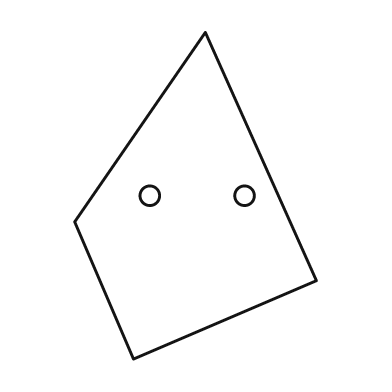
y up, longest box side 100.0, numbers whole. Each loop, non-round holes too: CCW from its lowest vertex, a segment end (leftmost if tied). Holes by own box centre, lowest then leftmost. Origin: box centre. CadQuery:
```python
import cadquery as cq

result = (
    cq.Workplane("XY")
    .moveTo(-19.0, -50.0)
    .lineTo(37.0, -26.0)
    .lineTo(3.0, 50.0)
    .lineTo(-37.0, -8.0)
    .close()
    .moveTo(-14.0, 0.0)
    .circle(3.0)
    .moveTo(15.0, 0.0)
    .circle(3.0)
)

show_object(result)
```